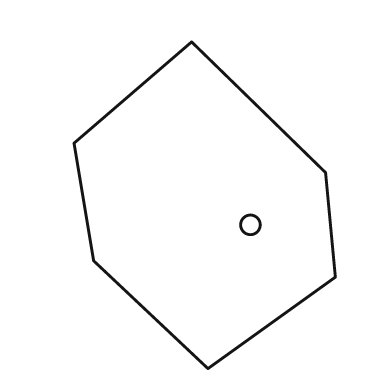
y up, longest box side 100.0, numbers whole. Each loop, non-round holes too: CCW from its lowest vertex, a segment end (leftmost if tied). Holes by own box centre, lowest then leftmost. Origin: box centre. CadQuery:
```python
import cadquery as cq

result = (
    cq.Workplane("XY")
    .moveTo(1.0, -50.0)
    .lineTo(40.0, -22.0)
    .lineTo(37.0, 10.0)
    .lineTo(-4.0, 50.0)
    .lineTo(-40.0, 19.0)
    .lineTo(-34.0, -17.0)
    .close()
    .moveTo(14.0, -6.0)
    .circle(3.0)
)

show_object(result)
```